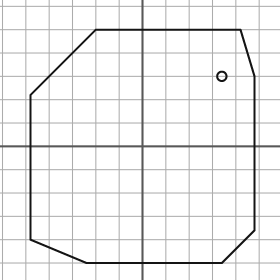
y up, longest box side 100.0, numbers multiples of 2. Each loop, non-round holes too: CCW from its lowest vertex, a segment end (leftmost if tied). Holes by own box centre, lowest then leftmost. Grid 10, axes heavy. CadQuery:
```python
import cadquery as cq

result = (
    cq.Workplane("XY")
    .moveTo(-24.0, -50.0)
    .lineTo(34.0, -50.0)
    .lineTo(48.0, -36.0)
    .lineTo(48.0, 30.0)
    .lineTo(42.0, 50.0)
    .lineTo(-20.0, 50.0)
    .lineTo(-48.0, 22.0)
    .lineTo(-48.0, -40.0)
    .close()
    .moveTo(34.0, 30.0)
    .circle(2.0)
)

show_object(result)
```